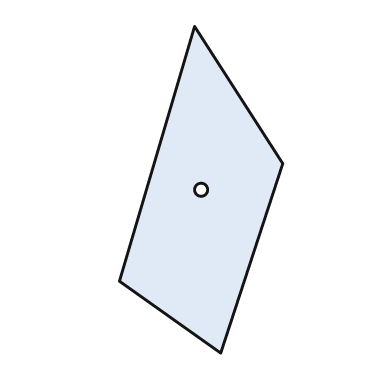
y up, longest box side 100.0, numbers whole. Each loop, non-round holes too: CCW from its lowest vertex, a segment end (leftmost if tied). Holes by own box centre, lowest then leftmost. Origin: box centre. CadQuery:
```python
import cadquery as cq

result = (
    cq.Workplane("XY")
    .moveTo(6.0, -50.0)
    .lineTo(25.0, 8.0)
    .lineTo(-2.0, 50.0)
    .lineTo(-25.0, -28.0)
    .close()
    .moveTo(0.0, 0.0)
    .circle(2.0)
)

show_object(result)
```